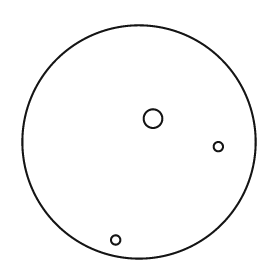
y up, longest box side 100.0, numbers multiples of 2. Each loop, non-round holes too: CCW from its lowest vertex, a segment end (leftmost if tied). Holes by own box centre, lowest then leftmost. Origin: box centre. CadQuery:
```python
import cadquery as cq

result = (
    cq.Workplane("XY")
    .moveTo(0.0, 0.0)
    .circle(50.0)
    .moveTo(-10.0, -42.0)
    .circle(2.0)
    .moveTo(34.0, -2.0)
    .circle(2.0)
    .moveTo(6.0, 10.0)
    .circle(4.0)
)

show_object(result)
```